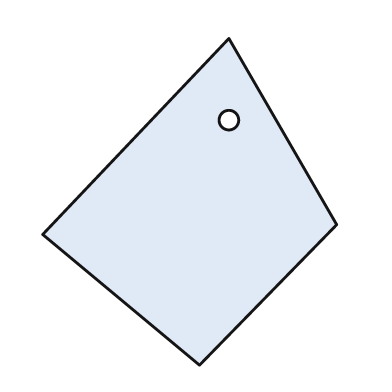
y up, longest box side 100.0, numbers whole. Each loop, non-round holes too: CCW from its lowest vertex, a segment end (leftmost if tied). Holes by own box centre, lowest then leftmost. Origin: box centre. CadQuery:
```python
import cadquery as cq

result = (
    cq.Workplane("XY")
    .moveTo(3.0, -50.0)
    .lineTo(45.0, -7.0)
    .lineTo(12.0, 50.0)
    .lineTo(-45.0, -10.0)
    .close()
    .moveTo(12.0, 25.0)
    .circle(3.0)
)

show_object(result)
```